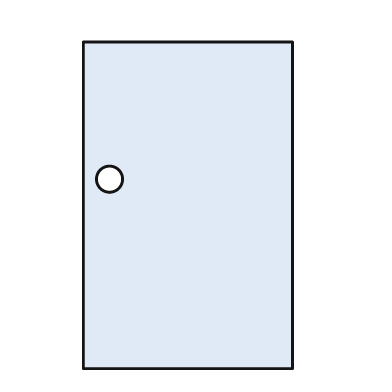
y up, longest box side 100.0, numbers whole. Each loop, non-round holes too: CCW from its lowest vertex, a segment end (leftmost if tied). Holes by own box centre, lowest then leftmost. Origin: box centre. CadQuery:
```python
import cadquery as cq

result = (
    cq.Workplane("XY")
    .moveTo(-32.0, -50.0)
    .lineTo(32.0, -50.0)
    .lineTo(32.0, 50.0)
    .lineTo(-32.0, 50.0)
    .close()
    .moveTo(-24.0, 8.0)
    .circle(4.0)
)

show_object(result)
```